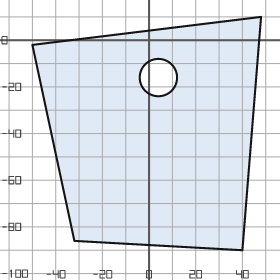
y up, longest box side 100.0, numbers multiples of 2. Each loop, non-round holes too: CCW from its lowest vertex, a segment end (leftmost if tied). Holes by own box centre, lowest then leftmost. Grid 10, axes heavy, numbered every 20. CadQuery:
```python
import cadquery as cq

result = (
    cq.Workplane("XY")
    .moveTo(40.0, -90.0)
    .lineTo(48.0, 10.0)
    .lineTo(-50.0, -2.0)
    .lineTo(-32.0, -86.0)
    .close()
    .moveTo(4.0, -16.0)
    .circle(8.0)
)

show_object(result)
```